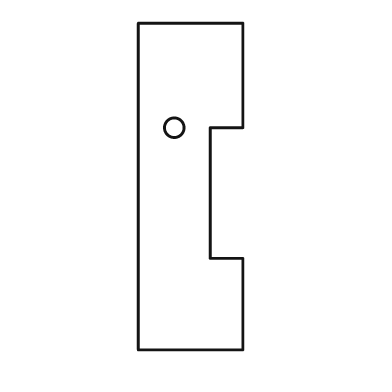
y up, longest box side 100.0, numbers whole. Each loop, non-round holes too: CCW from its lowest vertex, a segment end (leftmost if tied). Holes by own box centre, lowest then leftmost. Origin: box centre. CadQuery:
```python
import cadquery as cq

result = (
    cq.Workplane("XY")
    .moveTo(-16.0, -50.0)
    .lineTo(16.0, -50.0)
    .lineTo(16.0, -22.0)
    .lineTo(6.0, -22.0)
    .lineTo(6.0, 18.0)
    .lineTo(16.0, 18.0)
    .lineTo(16.0, 50.0)
    .lineTo(-16.0, 50.0)
    .close()
    .moveTo(-5.0, 18.0)
    .circle(3.0)
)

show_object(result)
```